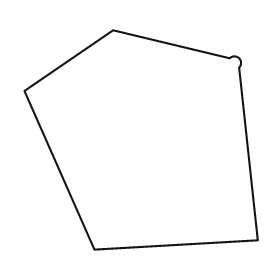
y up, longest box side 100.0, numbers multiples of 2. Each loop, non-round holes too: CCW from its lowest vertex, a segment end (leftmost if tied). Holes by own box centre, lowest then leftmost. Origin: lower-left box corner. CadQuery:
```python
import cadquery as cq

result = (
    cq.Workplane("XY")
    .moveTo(30.0, 0.0)
    .lineTo(100.0, 4.0)
    .lineTo(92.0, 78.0)
    .threePointArc((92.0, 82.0), (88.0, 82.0))
    .lineTo(38.0, 94.0)
    .lineTo(0.0, 68.0)
    .close()
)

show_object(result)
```